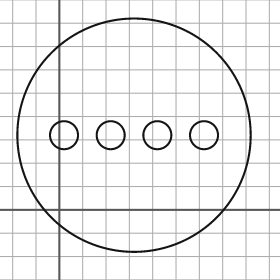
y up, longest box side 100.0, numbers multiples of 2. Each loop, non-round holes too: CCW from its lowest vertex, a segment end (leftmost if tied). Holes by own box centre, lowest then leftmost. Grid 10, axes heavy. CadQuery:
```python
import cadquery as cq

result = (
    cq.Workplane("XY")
    .moveTo(32.0, 32.0)
    .circle(50.0)
    .moveTo(2.0, 32.0)
    .circle(6.0)
    .moveTo(22.0, 32.0)
    .circle(6.0)
    .moveTo(42.0, 32.0)
    .circle(6.0)
    .moveTo(62.0, 32.0)
    .circle(6.0)
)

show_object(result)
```